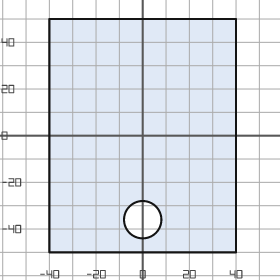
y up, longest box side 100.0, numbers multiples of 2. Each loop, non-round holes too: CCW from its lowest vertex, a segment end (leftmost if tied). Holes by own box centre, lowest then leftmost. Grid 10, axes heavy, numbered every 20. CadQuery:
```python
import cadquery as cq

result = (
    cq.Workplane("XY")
    .moveTo(-40.0, -50.0)
    .lineTo(40.0, -50.0)
    .lineTo(40.0, 50.0)
    .lineTo(-40.0, 50.0)
    .close()
    .moveTo(0.0, -36.0)
    .circle(8.0)
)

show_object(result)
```